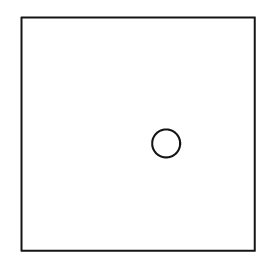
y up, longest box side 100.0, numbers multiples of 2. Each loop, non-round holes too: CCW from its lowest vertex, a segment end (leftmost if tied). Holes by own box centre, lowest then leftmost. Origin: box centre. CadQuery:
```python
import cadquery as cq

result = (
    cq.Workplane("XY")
    .moveTo(-50.0, -50.0)
    .lineTo(50.0, -50.0)
    .lineTo(50.0, 50.0)
    .lineTo(-50.0, 50.0)
    .close()
    .moveTo(12.0, -4.0)
    .circle(6.0)
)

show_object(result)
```